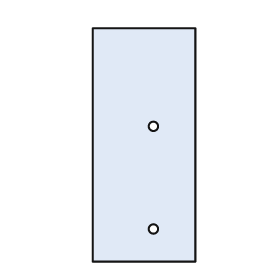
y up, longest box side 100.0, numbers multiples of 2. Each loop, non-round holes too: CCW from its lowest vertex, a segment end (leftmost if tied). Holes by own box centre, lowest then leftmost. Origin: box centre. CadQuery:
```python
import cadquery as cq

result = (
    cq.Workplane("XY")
    .moveTo(-22.0, -50.0)
    .lineTo(22.0, -50.0)
    .lineTo(22.0, 50.0)
    .lineTo(-22.0, 50.0)
    .close()
    .moveTo(4.0, -36.0)
    .circle(2.0)
    .moveTo(4.0, 8.0)
    .circle(2.0)
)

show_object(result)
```